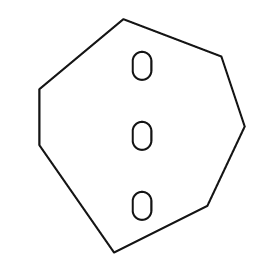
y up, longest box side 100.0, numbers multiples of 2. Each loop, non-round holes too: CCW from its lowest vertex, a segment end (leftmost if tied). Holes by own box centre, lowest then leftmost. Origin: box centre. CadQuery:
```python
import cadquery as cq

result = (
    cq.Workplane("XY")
    .moveTo(-12.0, -50.0)
    .lineTo(28.0, -30.0)
    .lineTo(44.0, 4.0)
    .lineTo(34.0, 34.0)
    .lineTo(-8.0, 50.0)
    .lineTo(-44.0, 20.0)
    .lineTo(-44.0, -4.0)
    .close()
    .moveTo(-4.0, -32.0)
    .threePointArc((0.0, -36.0), (4.0, -32.0))
    .lineTo(4.0, -28.0)
    .threePointArc((0.0, -24.0), (-4.0, -28.0))
    .close()
    .moveTo(-4.0, -2.0)
    .threePointArc((0.0, -6.0), (4.0, -2.0))
    .lineTo(4.0, 2.0)
    .threePointArc((0.0, 6.0), (-4.0, 2.0))
    .close()
    .moveTo(-4.0, 28.0)
    .threePointArc((0.0, 24.0), (4.0, 28.0))
    .lineTo(4.0, 32.0)
    .threePointArc((0.0, 36.0), (-4.0, 32.0))
    .close()
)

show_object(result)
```